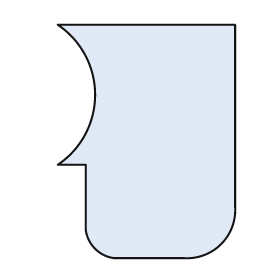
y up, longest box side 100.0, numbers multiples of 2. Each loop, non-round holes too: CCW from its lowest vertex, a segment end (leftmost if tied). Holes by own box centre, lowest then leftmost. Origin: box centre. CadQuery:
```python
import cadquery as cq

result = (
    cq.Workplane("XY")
    .moveTo(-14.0, -50.0)
    .lineTo(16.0, -50.0)
    .threePointArc((32.0, -44.0), (38.0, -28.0))
    .lineTo(38.0, 50.0)
    .lineTo(-38.0, 50.0)
    .threePointArc((-22.0, 20.0), (-38.0, -10.0))
    .lineTo(-26.0, -10.0)
    .lineTo(-26.0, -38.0)
    .threePointArc((-22.0, -46.0), (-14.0, -50.0))
    .close()
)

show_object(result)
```